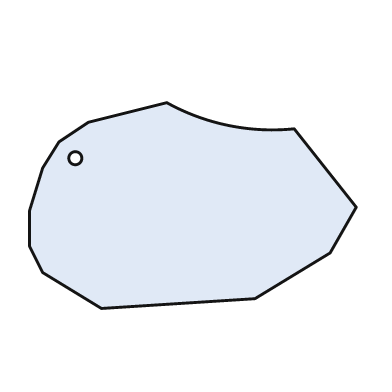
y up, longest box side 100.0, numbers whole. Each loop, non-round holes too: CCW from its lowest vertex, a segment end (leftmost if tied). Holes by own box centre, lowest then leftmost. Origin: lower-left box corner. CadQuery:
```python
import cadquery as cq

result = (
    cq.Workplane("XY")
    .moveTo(22.0, 0.0)
    .lineTo(69.0, 3.0)
    .lineTo(92.0, 17.0)
    .lineTo(100.0, 31.0)
    .lineTo(81.0, 55.0)
    .threePointArc((61.0, 56.0), (42.0, 63.0))
    .lineTo(18.0, 57.0)
    .lineTo(9.0, 51.0)
    .lineTo(4.0, 43.0)
    .lineTo(0.0, 30.0)
    .lineTo(0.0, 19.0)
    .lineTo(4.0, 11.0)
    .close()
    .moveTo(14.0, 46.0)
    .circle(2.0)
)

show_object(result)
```